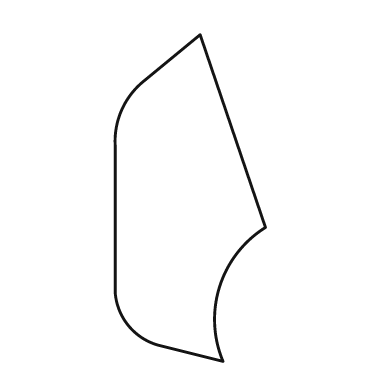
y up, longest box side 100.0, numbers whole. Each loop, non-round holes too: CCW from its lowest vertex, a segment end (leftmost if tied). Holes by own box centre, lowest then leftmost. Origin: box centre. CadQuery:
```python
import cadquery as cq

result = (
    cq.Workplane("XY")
    .moveTo(10.0, -50.0)
    .threePointArc((9.0, -27.0), (23.0, -9.0))
    .lineTo(3.0, 50.0)
    .lineTo(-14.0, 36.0)
    .threePointArc((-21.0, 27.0), (-23.0, 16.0))
    .lineTo(-23.0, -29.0)
    .threePointArc((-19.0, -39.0), (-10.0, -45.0))
    .close()
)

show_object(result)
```